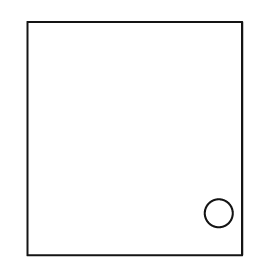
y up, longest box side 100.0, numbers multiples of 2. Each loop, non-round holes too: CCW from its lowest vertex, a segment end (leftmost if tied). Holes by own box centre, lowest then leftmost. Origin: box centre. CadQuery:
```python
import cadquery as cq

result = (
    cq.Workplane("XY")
    .moveTo(-46.0, -50.0)
    .lineTo(46.0, -50.0)
    .lineTo(46.0, 50.0)
    .lineTo(-46.0, 50.0)
    .close()
    .moveTo(36.0, -32.0)
    .circle(6.0)
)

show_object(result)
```